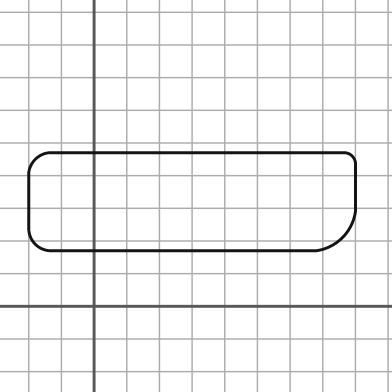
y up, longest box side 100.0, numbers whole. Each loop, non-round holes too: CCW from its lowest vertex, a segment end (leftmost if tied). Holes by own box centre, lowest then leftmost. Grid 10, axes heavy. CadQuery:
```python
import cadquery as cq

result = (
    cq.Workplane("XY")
    .moveTo(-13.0, 17.0)
    .lineTo(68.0, 17.0)
    .threePointArc((76.0, 21.0), (80.0, 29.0))
    .lineTo(80.0, 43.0)
    .threePointArc((79.0, 46.0), (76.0, 47.0))
    .lineTo(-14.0, 47.0)
    .threePointArc((-18.0, 45.0), (-20.0, 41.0))
    .lineTo(-20.0, 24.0)
    .threePointArc((-18.0, 19.0), (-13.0, 17.0))
    .close()
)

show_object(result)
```